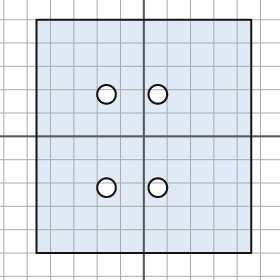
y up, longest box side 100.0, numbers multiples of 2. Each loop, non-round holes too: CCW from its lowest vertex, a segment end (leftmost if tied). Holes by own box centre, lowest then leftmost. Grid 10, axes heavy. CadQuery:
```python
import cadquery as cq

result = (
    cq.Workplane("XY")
    .moveTo(-46.0, -50.0)
    .lineTo(46.0, -50.0)
    .lineTo(46.0, 50.0)
    .lineTo(-46.0, 50.0)
    .close()
    .moveTo(-16.0, -22.0)
    .circle(4.0)
    .moveTo(6.0, -22.0)
    .circle(4.0)
    .moveTo(-16.0, 18.0)
    .circle(4.0)
    .moveTo(6.0, 18.0)
    .circle(4.0)
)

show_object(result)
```